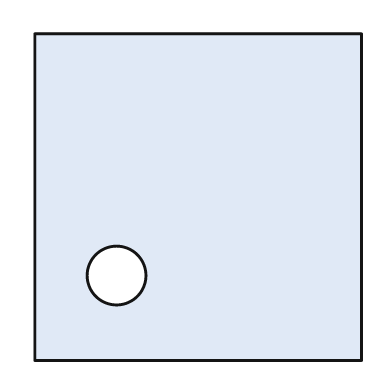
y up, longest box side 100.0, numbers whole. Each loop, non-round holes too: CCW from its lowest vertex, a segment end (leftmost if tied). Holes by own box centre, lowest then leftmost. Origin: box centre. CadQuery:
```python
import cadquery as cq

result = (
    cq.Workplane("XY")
    .moveTo(-50.0, -50.0)
    .lineTo(50.0, -50.0)
    .lineTo(50.0, 50.0)
    .lineTo(-50.0, 50.0)
    .close()
    .moveTo(-25.0, -24.0)
    .circle(9.0)
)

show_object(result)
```